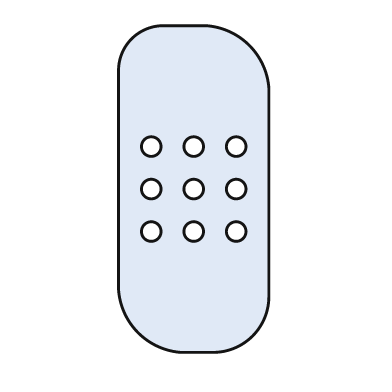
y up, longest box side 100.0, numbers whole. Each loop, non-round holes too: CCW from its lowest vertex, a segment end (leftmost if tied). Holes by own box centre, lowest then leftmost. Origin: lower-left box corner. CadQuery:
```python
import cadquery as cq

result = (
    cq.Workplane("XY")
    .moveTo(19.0, 0.0)
    .lineTo(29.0, 0.0)
    .threePointArc((41.0, 5.0), (46.0, 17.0))
    .lineTo(46.0, 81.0)
    .threePointArc((40.0, 94.0), (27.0, 100.0))
    .lineTo(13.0, 100.0)
    .threePointArc((4.0, 96.0), (0.0, 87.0))
    .lineTo(0.0, 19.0)
    .threePointArc((6.0, 6.0), (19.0, 0.0))
    .close()
    .moveTo(10.0, 37.0)
    .circle(3.0)
    .moveTo(23.0, 37.0)
    .circle(3.0)
    .moveTo(36.0, 37.0)
    .circle(3.0)
    .moveTo(10.0, 50.0)
    .circle(3.0)
    .moveTo(23.0, 50.0)
    .circle(3.0)
    .moveTo(36.0, 50.0)
    .circle(3.0)
    .moveTo(10.0, 63.0)
    .circle(3.0)
    .moveTo(23.0, 63.0)
    .circle(3.0)
    .moveTo(36.0, 63.0)
    .circle(3.0)
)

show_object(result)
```